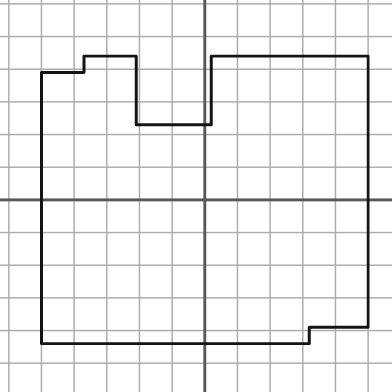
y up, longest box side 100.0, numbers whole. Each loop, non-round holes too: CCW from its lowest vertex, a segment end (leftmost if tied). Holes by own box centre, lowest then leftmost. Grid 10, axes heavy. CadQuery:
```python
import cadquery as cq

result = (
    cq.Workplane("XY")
    .moveTo(-50.0, -44.0)
    .lineTo(32.0, -44.0)
    .lineTo(32.0, -39.0)
    .lineTo(50.0, -39.0)
    .lineTo(50.0, 44.0)
    .lineTo(2.0, 44.0)
    .lineTo(2.0, 23.0)
    .lineTo(-21.0, 23.0)
    .lineTo(-21.0, 44.0)
    .lineTo(-37.0, 44.0)
    .lineTo(-37.0, 39.0)
    .lineTo(-50.0, 39.0)
    .close()
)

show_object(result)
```